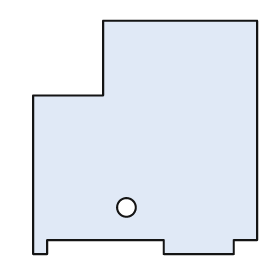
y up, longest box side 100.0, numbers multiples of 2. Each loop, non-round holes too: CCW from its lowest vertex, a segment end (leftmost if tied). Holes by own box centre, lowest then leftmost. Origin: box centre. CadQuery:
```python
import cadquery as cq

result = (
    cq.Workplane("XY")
    .moveTo(-48.0, -50.0)
    .lineTo(-42.0, -50.0)
    .lineTo(-42.0, -44.0)
    .lineTo(8.0, -44.0)
    .lineTo(8.0, -50.0)
    .lineTo(38.0, -50.0)
    .lineTo(38.0, -44.0)
    .lineTo(48.0, -44.0)
    .lineTo(48.0, 50.0)
    .lineTo(-18.0, 50.0)
    .lineTo(-18.0, 18.0)
    .lineTo(-48.0, 18.0)
    .close()
    .moveTo(-8.0, -30.0)
    .circle(4.0)
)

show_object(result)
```